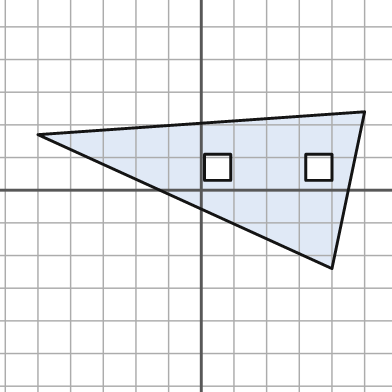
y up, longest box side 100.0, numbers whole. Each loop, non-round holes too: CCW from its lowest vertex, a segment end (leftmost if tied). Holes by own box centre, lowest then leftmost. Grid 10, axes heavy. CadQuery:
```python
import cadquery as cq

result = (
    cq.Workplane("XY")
    .moveTo(40.0, -24.0)
    .lineTo(50.0, 24.0)
    .lineTo(-50.0, 17.0)
    .close()
    .moveTo(1.0, 3.0)
    .lineTo(9.0, 3.0)
    .lineTo(9.0, 11.0)
    .lineTo(1.0, 11.0)
    .close()
    .moveTo(32.0, 3.0)
    .lineTo(40.0, 3.0)
    .lineTo(40.0, 11.0)
    .lineTo(32.0, 11.0)
    .close()
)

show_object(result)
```